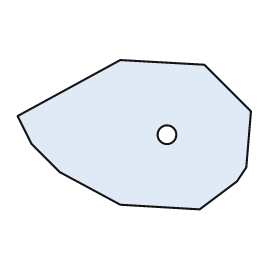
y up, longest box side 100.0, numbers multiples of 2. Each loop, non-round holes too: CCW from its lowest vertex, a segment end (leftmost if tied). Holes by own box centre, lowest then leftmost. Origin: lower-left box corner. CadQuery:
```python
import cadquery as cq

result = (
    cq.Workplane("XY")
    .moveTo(78.0, 0.0)
    .lineTo(94.0, 12.0)
    .lineTo(98.0, 18.0)
    .lineTo(100.0, 42.0)
    .lineTo(80.0, 62.0)
    .lineTo(44.0, 64.0)
    .lineTo(0.0, 40.0)
    .lineTo(6.0, 28.0)
    .lineTo(18.0, 16.0)
    .lineTo(44.0, 2.0)
    .close()
    .moveTo(64.0, 32.0)
    .circle(4.0)
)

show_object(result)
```